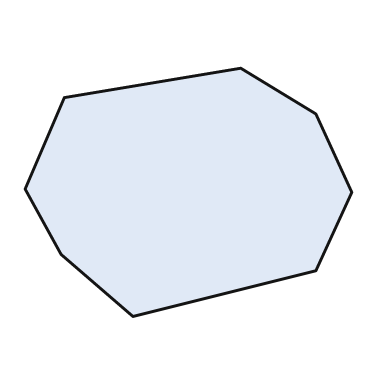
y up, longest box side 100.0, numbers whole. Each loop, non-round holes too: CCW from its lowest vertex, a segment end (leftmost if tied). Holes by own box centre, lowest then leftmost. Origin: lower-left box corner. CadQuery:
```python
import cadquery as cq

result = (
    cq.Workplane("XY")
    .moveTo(33.0, 0.0)
    .lineTo(89.0, 14.0)
    .lineTo(100.0, 38.0)
    .lineTo(89.0, 62.0)
    .lineTo(66.0, 76.0)
    .lineTo(12.0, 67.0)
    .lineTo(0.0, 39.0)
    .lineTo(11.0, 19.0)
    .close()
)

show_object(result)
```